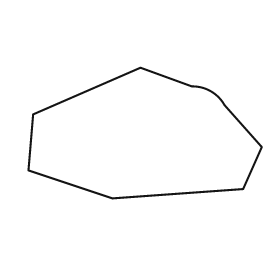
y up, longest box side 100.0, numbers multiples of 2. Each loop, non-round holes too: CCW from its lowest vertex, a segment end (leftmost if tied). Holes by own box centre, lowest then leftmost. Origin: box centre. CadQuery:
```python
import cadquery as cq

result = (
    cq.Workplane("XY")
    .moveTo(-14.0, -28.0)
    .lineTo(42.0, -24.0)
    .lineTo(50.0, -6.0)
    .lineTo(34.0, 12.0)
    .threePointArc((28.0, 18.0), (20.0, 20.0))
    .lineTo(-2.0, 28.0)
    .lineTo(-48.0, 8.0)
    .lineTo(-50.0, -16.0)
    .close()
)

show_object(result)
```